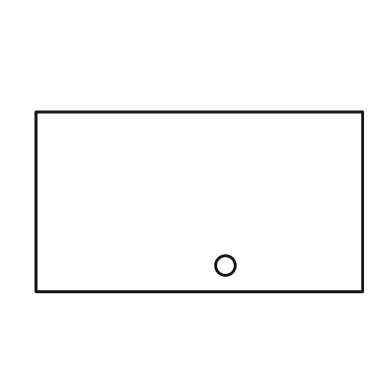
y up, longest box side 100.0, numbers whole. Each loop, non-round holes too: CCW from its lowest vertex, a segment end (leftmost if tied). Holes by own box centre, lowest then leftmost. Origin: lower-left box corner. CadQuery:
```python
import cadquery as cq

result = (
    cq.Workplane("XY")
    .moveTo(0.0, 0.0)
    .lineTo(100.0, 0.0)
    .lineTo(100.0, 55.0)
    .lineTo(0.0, 55.0)
    .close()
    .moveTo(58.0, 8.0)
    .circle(3.0)
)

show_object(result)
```